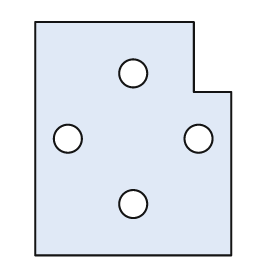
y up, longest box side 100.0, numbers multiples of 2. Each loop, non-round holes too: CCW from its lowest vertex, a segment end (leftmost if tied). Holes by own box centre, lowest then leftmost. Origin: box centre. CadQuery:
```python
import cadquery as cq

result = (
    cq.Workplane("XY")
    .moveTo(-42.0, -50.0)
    .lineTo(42.0, -50.0)
    .lineTo(42.0, 20.0)
    .lineTo(26.0, 20.0)
    .lineTo(26.0, 50.0)
    .lineTo(-42.0, 50.0)
    .close()
    .moveTo(0.0, -28.0)
    .circle(6.0)
    .moveTo(-28.0, 0.0)
    .circle(6.0)
    .moveTo(28.0, 0.0)
    .circle(6.0)
    .moveTo(0.0, 28.0)
    .circle(6.0)
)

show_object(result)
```